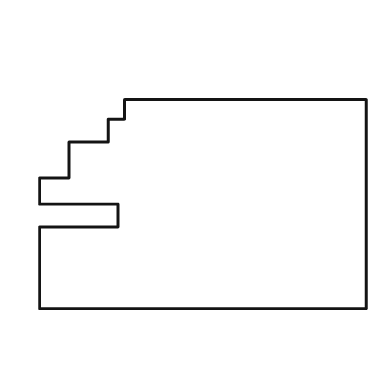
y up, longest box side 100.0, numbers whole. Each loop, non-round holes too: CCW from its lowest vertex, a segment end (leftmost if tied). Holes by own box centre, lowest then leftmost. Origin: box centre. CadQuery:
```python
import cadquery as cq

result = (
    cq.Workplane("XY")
    .moveTo(-50.0, -32.0)
    .lineTo(50.0, -32.0)
    .lineTo(50.0, 32.0)
    .lineTo(-24.0, 32.0)
    .lineTo(-24.0, 26.0)
    .lineTo(-29.0, 26.0)
    .lineTo(-29.0, 19.0)
    .lineTo(-41.0, 19.0)
    .lineTo(-41.0, 8.0)
    .lineTo(-50.0, 8.0)
    .lineTo(-50.0, 0.0)
    .lineTo(-26.0, 0.0)
    .lineTo(-26.0, -7.0)
    .lineTo(-50.0, -7.0)
    .close()
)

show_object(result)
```